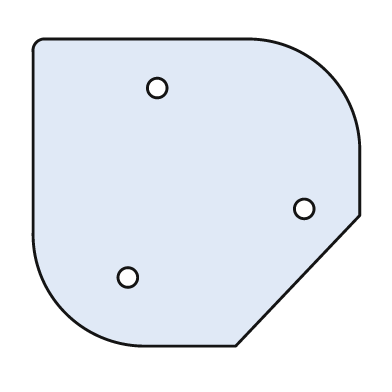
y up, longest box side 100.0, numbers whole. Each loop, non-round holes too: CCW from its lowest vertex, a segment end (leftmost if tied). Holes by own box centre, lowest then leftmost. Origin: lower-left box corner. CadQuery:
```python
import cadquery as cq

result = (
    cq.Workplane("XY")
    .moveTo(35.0, 0.0)
    .lineTo(62.0, 0.0)
    .lineTo(100.0, 40.0)
    .lineTo(100.0, 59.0)
    .threePointArc((90.0, 84.0), (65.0, 94.0))
    .lineTo(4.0, 94.0)
    .threePointArc((1.0, 93.0), (0.0, 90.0))
    .lineTo(0.0, 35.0)
    .threePointArc((10.0, 10.0), (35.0, 0.0))
    .close()
    .moveTo(29.0, 21.0)
    .circle(3.0)
    .moveTo(83.0, 42.0)
    .circle(3.0)
    .moveTo(38.0, 79.0)
    .circle(3.0)
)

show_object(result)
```